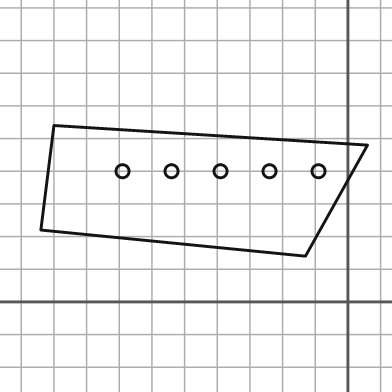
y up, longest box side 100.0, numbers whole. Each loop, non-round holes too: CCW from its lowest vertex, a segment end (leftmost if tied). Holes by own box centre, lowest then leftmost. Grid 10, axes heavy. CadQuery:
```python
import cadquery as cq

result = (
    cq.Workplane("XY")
    .moveTo(-13.0, 14.0)
    .lineTo(6.0, 48.0)
    .lineTo(-90.0, 54.0)
    .lineTo(-94.0, 22.0)
    .close()
    .moveTo(-69.0, 40.0)
    .circle(2.0)
    .moveTo(-54.0, 40.0)
    .circle(2.0)
    .moveTo(-39.0, 40.0)
    .circle(2.0)
    .moveTo(-24.0, 40.0)
    .circle(2.0)
    .moveTo(-9.0, 40.0)
    .circle(2.0)
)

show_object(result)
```